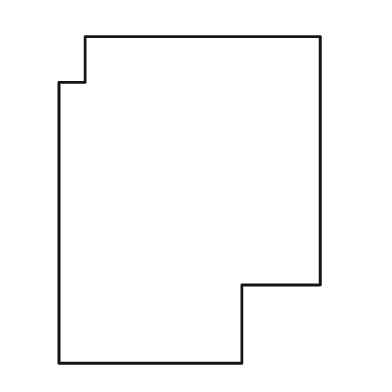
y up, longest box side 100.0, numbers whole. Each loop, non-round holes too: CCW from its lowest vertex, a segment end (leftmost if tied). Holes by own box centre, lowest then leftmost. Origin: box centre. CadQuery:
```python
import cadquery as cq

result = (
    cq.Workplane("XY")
    .moveTo(-40.0, -50.0)
    .lineTo(16.0, -50.0)
    .lineTo(16.0, -26.0)
    .lineTo(40.0, -26.0)
    .lineTo(40.0, 50.0)
    .lineTo(-32.0, 50.0)
    .lineTo(-32.0, 36.0)
    .lineTo(-40.0, 36.0)
    .close()
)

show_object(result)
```